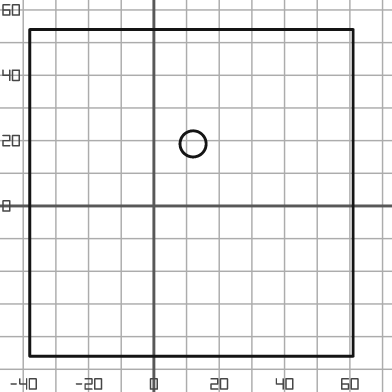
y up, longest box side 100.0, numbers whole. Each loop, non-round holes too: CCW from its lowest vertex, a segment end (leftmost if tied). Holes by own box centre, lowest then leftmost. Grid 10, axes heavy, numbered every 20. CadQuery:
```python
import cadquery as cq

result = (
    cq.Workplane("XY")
    .moveTo(-38.0, -46.0)
    .lineTo(61.0, -46.0)
    .lineTo(61.0, 54.0)
    .lineTo(-38.0, 54.0)
    .close()
    .moveTo(12.0, 19.0)
    .circle(4.0)
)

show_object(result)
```